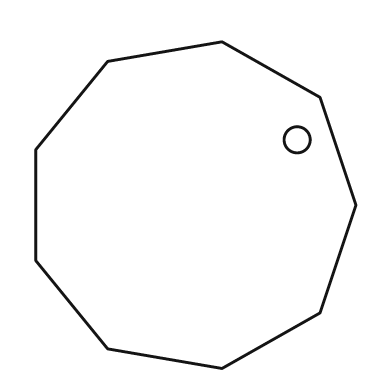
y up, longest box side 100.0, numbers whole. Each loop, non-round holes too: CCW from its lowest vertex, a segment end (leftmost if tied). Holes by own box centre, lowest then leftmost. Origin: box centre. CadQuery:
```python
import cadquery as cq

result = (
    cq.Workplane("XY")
    .moveTo(8.0, -50.0)
    .lineTo(38.0, -33.0)
    .lineTo(49.0, 0.0)
    .lineTo(38.0, 33.0)
    .lineTo(8.0, 50.0)
    .lineTo(-27.0, 44.0)
    .lineTo(-49.0, 17.0)
    .lineTo(-49.0, -17.0)
    .lineTo(-27.0, -44.0)
    .close()
    .moveTo(31.0, 20.0)
    .circle(4.0)
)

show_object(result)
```